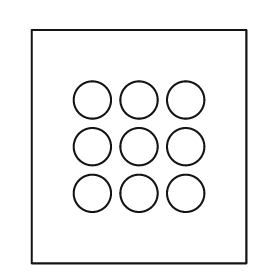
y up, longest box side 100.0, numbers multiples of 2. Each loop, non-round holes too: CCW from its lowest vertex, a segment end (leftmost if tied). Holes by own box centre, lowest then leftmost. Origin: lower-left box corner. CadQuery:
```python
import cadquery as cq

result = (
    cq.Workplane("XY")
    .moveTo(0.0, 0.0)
    .lineTo(92.0, 0.0)
    .lineTo(92.0, 100.0)
    .lineTo(0.0, 100.0)
    .close()
    .moveTo(26.0, 30.0)
    .circle(8.0)
    .moveTo(46.0, 30.0)
    .circle(8.0)
    .moveTo(66.0, 30.0)
    .circle(8.0)
    .moveTo(26.0, 50.0)
    .circle(8.0)
    .moveTo(46.0, 50.0)
    .circle(8.0)
    .moveTo(66.0, 50.0)
    .circle(8.0)
    .moveTo(26.0, 70.0)
    .circle(8.0)
    .moveTo(46.0, 70.0)
    .circle(8.0)
    .moveTo(66.0, 70.0)
    .circle(8.0)
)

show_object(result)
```